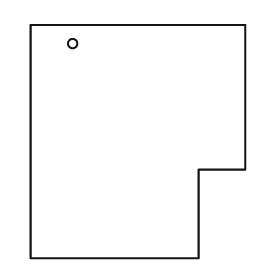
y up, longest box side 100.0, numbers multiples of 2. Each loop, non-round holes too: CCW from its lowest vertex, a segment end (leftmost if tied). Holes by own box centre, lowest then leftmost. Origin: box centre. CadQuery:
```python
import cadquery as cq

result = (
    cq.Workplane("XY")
    .moveTo(-46.0, -50.0)
    .lineTo(26.0, -50.0)
    .lineTo(26.0, -12.0)
    .lineTo(46.0, -12.0)
    .lineTo(46.0, 50.0)
    .lineTo(-46.0, 50.0)
    .close()
    .moveTo(-28.0, 42.0)
    .circle(2.0)
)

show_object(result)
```